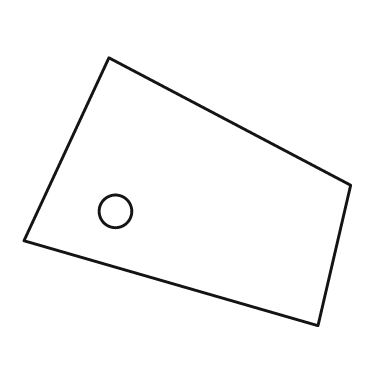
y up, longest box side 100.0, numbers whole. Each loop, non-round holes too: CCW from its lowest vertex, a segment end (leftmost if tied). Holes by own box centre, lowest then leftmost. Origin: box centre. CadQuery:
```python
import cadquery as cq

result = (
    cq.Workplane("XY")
    .moveTo(40.0, -41.0)
    .lineTo(50.0, 2.0)
    .lineTo(-24.0, 41.0)
    .lineTo(-50.0, -15.0)
    .close()
    .moveTo(-22.0, -6.0)
    .circle(5.0)
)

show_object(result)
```